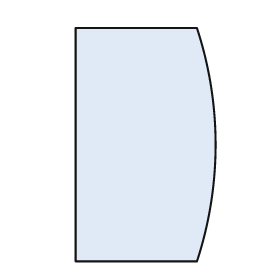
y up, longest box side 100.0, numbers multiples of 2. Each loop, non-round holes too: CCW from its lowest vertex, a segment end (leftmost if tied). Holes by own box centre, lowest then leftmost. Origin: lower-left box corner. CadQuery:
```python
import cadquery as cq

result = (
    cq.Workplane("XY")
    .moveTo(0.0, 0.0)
    .lineTo(52.0, 0.0)
    .threePointArc((60.0, 50.0), (52.0, 100.0))
    .lineTo(0.0, 100.0)
    .close()
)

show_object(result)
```